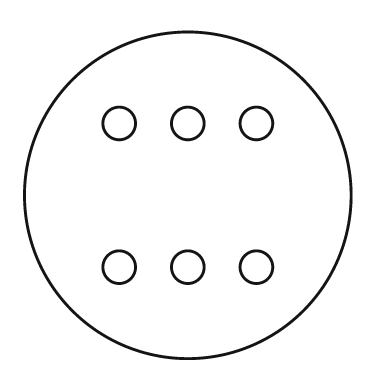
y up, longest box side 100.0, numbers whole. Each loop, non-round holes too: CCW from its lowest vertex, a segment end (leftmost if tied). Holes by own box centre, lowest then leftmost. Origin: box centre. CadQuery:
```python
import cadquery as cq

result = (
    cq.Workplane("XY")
    .moveTo(0.0, 0.0)
    .circle(50.0)
    .moveTo(-21.0, -22.0)
    .circle(5.0)
    .moveTo(0.0, -22.0)
    .circle(5.0)
    .moveTo(21.0, -22.0)
    .circle(5.0)
    .moveTo(-21.0, 22.0)
    .circle(5.0)
    .moveTo(0.0, 22.0)
    .circle(5.0)
    .moveTo(21.0, 22.0)
    .circle(5.0)
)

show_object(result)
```